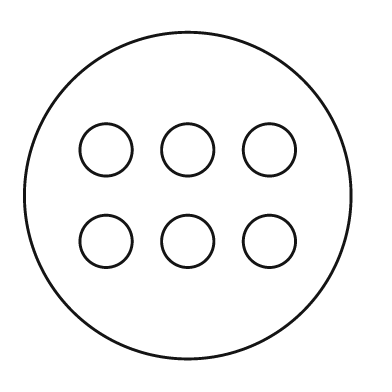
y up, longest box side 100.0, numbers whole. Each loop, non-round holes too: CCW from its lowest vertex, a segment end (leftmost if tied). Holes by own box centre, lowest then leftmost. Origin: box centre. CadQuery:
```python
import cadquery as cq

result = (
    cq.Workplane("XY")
    .moveTo(0.0, 0.0)
    .circle(50.0)
    .moveTo(-25.0, -14.0)
    .circle(8.0)
    .moveTo(0.0, -14.0)
    .circle(8.0)
    .moveTo(25.0, -14.0)
    .circle(8.0)
    .moveTo(-25.0, 14.0)
    .circle(8.0)
    .moveTo(0.0, 14.0)
    .circle(8.0)
    .moveTo(25.0, 14.0)
    .circle(8.0)
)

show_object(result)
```